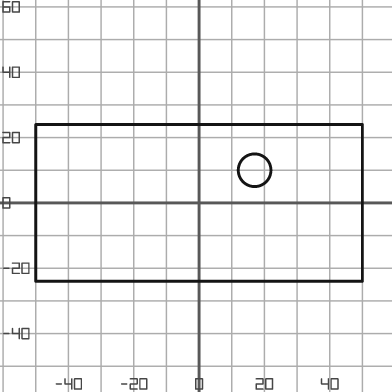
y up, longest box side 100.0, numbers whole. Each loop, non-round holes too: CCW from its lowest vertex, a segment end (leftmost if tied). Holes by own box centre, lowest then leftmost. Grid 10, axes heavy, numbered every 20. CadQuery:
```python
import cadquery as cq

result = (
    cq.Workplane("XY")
    .moveTo(-50.0, -24.0)
    .lineTo(50.0, -24.0)
    .lineTo(50.0, 24.0)
    .lineTo(-50.0, 24.0)
    .close()
    .moveTo(17.0, 10.0)
    .circle(5.0)
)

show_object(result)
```